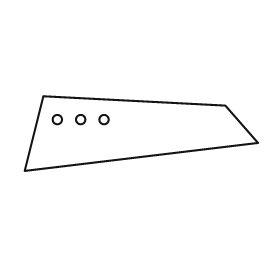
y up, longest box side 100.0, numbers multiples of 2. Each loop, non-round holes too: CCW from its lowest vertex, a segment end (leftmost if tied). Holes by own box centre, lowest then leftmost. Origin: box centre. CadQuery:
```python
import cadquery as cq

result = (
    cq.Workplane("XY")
    .moveTo(-50.0, -16.0)
    .lineTo(50.0, -4.0)
    .lineTo(36.0, 12.0)
    .lineTo(-42.0, 16.0)
    .close()
    .moveTo(-36.0, 6.0)
    .circle(2.0)
    .moveTo(-26.0, 6.0)
    .circle(2.0)
    .moveTo(-16.0, 6.0)
    .circle(2.0)
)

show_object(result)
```